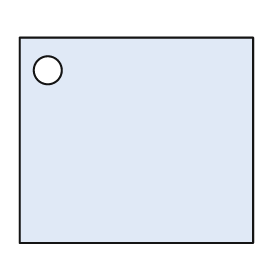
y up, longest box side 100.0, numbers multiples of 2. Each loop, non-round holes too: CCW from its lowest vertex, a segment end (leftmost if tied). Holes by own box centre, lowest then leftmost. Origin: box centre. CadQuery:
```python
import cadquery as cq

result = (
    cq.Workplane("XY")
    .moveTo(-50.0, -44.0)
    .lineTo(50.0, -44.0)
    .lineTo(50.0, 44.0)
    .lineTo(-50.0, 44.0)
    .close()
    .moveTo(-38.0, 30.0)
    .circle(6.0)
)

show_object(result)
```